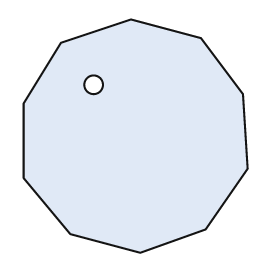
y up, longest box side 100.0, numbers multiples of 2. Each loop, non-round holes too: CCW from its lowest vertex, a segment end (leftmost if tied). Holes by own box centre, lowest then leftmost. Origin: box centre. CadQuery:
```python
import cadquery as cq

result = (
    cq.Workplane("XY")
    .moveTo(2.0, -50.0)
    .lineTo(30.0, -40.0)
    .lineTo(48.0, -14.0)
    .lineTo(46.0, 18.0)
    .lineTo(28.0, 42.0)
    .lineTo(-2.0, 50.0)
    .lineTo(-32.0, 40.0)
    .lineTo(-48.0, 14.0)
    .lineTo(-48.0, -18.0)
    .lineTo(-28.0, -42.0)
    .close()
    .moveTo(-18.0, 22.0)
    .circle(4.0)
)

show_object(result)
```